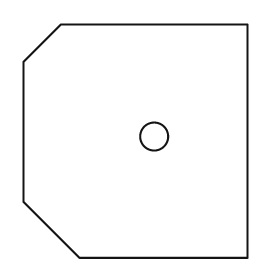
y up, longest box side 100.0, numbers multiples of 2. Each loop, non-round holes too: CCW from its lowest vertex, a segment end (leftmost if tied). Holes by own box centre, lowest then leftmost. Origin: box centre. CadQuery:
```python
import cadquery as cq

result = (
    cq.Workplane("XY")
    .moveTo(-24.0, -50.0)
    .lineTo(48.0, -50.0)
    .lineTo(48.0, 50.0)
    .lineTo(-32.0, 50.0)
    .lineTo(-48.0, 34.0)
    .lineTo(-48.0, -26.0)
    .close()
    .moveTo(8.0, 2.0)
    .circle(6.0)
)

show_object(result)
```